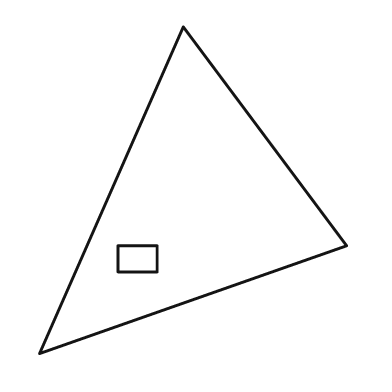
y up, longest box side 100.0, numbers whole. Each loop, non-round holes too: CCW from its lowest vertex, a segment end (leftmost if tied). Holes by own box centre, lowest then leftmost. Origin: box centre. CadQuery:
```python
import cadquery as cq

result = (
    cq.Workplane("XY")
    .moveTo(-47.0, -50.0)
    .lineTo(47.0, -17.0)
    .lineTo(-3.0, 50.0)
    .close()
    .moveTo(-23.0, -25.0)
    .lineTo(-11.0, -25.0)
    .lineTo(-11.0, -17.0)
    .lineTo(-23.0, -17.0)
    .close()
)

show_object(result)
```